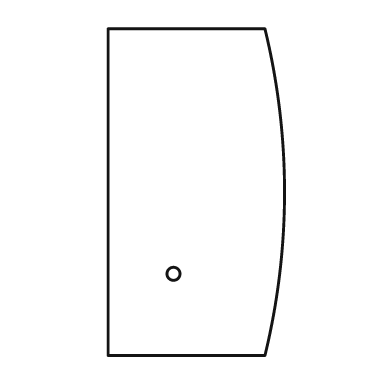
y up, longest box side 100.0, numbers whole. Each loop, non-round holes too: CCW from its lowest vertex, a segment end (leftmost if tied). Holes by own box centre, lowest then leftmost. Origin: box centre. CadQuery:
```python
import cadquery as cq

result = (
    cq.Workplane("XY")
    .moveTo(-27.0, -50.0)
    .lineTo(21.0, -50.0)
    .threePointArc((27.0, 0.0), (21.0, 50.0))
    .lineTo(-27.0, 50.0)
    .close()
    .moveTo(-7.0, -25.0)
    .circle(2.0)
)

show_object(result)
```